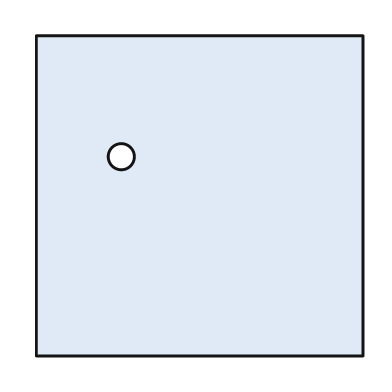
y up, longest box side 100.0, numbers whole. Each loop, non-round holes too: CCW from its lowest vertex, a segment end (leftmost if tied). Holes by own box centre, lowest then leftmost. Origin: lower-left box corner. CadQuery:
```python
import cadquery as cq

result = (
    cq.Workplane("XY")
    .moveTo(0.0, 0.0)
    .lineTo(100.0, 0.0)
    .lineTo(100.0, 98.0)
    .lineTo(0.0, 98.0)
    .close()
    .moveTo(26.0, 61.0)
    .circle(4.0)
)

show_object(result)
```